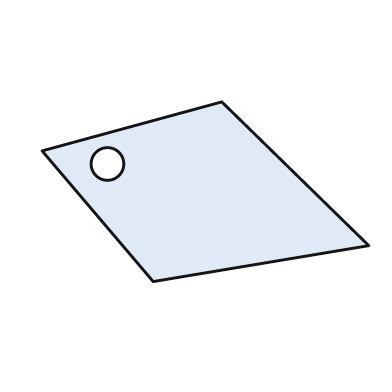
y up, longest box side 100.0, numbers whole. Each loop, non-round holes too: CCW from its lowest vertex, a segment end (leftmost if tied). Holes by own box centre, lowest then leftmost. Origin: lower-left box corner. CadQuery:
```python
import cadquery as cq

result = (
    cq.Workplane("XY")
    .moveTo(34.0, 0.0)
    .lineTo(100.0, 11.0)
    .lineTo(55.0, 55.0)
    .lineTo(0.0, 40.0)
    .close()
    .moveTo(20.0, 36.0)
    .circle(5.0)
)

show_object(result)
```